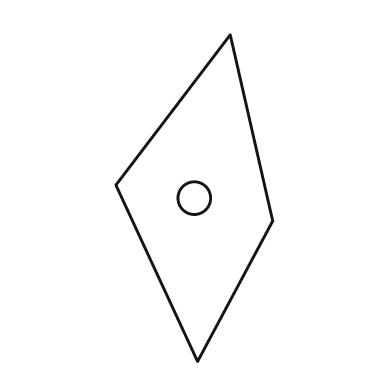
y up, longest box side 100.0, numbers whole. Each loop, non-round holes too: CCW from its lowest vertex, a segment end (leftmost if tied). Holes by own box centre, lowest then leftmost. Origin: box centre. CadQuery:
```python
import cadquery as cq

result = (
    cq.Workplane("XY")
    .moveTo(1.0, -50.0)
    .lineTo(24.0, -7.0)
    .lineTo(11.0, 50.0)
    .lineTo(-24.0, 4.0)
    .close()
    .moveTo(0.0, 0.0)
    .circle(5.0)
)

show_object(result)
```